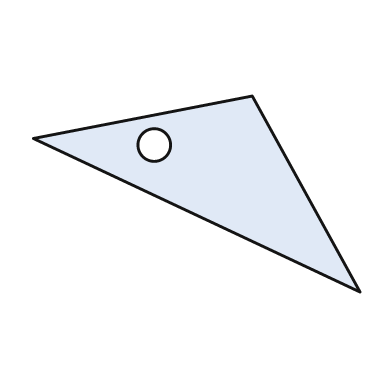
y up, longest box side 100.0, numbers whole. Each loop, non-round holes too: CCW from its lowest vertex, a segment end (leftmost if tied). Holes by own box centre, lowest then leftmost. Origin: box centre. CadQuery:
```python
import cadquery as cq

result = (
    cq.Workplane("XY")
    .moveTo(50.0, -30.0)
    .lineTo(17.0, 30.0)
    .lineTo(-50.0, 17.0)
    .close()
    .moveTo(-13.0, 15.0)
    .circle(5.0)
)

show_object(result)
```